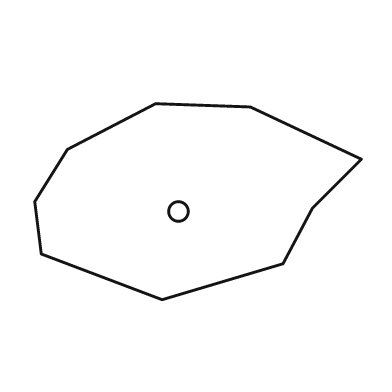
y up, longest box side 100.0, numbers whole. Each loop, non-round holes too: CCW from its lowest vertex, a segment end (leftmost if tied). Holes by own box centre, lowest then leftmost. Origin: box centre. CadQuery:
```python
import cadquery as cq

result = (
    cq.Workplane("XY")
    .moveTo(-11.0, -30.0)
    .lineTo(26.0, -19.0)
    .lineTo(35.0, -2.0)
    .lineTo(50.0, 13.0)
    .lineTo(16.0, 29.0)
    .lineTo(-13.0, 30.0)
    .lineTo(-40.0, 16.0)
    .lineTo(-50.0, 0.0)
    .lineTo(-48.0, -16.0)
    .close()
    .moveTo(-6.0, -3.0)
    .circle(3.0)
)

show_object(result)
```